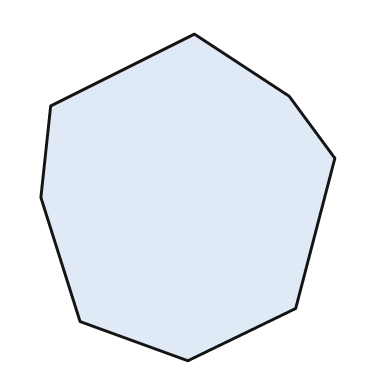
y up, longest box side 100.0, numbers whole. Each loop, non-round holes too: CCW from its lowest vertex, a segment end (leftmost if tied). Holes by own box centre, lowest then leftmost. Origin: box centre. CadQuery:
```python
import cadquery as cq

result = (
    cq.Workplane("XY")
    .moveTo(0.0, -50.0)
    .lineTo(33.0, -34.0)
    .lineTo(45.0, 12.0)
    .lineTo(31.0, 31.0)
    .lineTo(2.0, 50.0)
    .lineTo(-42.0, 28.0)
    .lineTo(-45.0, 0.0)
    .lineTo(-33.0, -38.0)
    .close()
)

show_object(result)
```